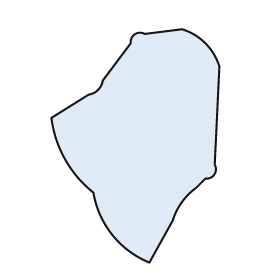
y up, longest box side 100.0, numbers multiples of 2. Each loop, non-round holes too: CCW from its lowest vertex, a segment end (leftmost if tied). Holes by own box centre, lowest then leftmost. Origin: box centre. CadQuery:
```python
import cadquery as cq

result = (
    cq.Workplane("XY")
    .moveTo(6.0, -50.0)
    .lineTo(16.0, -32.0)
    .threePointArc((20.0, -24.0), (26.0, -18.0))
    .lineTo(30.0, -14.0)
    .threePointArc((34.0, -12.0), (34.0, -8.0))
    .lineTo(36.0, 34.0)
    .threePointArc((30.0, 44.0), (20.0, 50.0))
    .lineTo(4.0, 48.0)
    .threePointArc((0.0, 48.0), (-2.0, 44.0))
    .lineTo(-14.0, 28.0)
    .threePointArc((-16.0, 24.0), (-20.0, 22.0))
    .lineTo(-36.0, 12.0)
    .threePointArc((-30.0, -6.0), (-18.0, -20.0))
    .threePointArc((-10.0, -38.0), (6.0, -50.0))
    .close()
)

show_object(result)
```